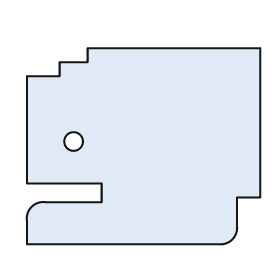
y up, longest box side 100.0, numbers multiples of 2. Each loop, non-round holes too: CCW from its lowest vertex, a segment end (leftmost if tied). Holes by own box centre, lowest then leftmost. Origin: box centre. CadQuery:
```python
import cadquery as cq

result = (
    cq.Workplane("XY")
    .moveTo(-50.0, -42.0)
    .lineTo(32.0, -42.0)
    .threePointArc((38.0, -40.0), (40.0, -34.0))
    .lineTo(40.0, -22.0)
    .lineTo(50.0, -22.0)
    .lineTo(50.0, 42.0)
    .lineTo(-24.0, 42.0)
    .lineTo(-24.0, 36.0)
    .lineTo(-36.0, 36.0)
    .lineTo(-36.0, 30.0)
    .lineTo(-50.0, 30.0)
    .lineTo(-50.0, -16.0)
    .lineTo(-18.0, -16.0)
    .lineTo(-18.0, -24.0)
    .lineTo(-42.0, -24.0)
    .threePointArc((-48.0, -26.0), (-50.0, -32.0))
    .close()
    .moveTo(-30.0, 2.0)
    .circle(4.0)
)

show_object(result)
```